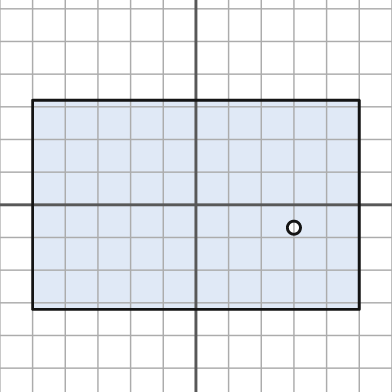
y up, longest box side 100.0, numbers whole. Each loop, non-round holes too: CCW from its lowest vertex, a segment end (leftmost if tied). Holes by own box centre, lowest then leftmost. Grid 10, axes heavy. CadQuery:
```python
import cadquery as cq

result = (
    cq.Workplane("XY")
    .moveTo(-50.0, -32.0)
    .lineTo(50.0, -32.0)
    .lineTo(50.0, 32.0)
    .lineTo(-50.0, 32.0)
    .close()
    .moveTo(30.0, -7.0)
    .circle(2.0)
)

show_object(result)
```